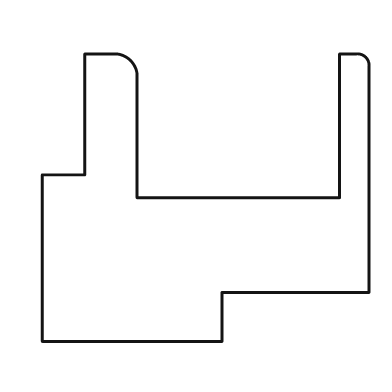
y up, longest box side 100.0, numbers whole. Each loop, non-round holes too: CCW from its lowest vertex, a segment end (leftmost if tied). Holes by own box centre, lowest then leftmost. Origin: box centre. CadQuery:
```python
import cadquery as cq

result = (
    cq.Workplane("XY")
    .moveTo(-50.0, -44.0)
    .lineTo(5.0, -44.0)
    .lineTo(5.0, -29.0)
    .lineTo(50.0, -29.0)
    .lineTo(50.0, 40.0)
    .threePointArc((49.0, 43.0), (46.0, 44.0))
    .lineTo(41.0, 44.0)
    .lineTo(41.0, 0.0)
    .lineTo(-21.0, 0.0)
    .lineTo(-21.0, 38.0)
    .threePointArc((-23.0, 42.0), (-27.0, 44.0))
    .lineTo(-37.0, 44.0)
    .lineTo(-37.0, 7.0)
    .lineTo(-50.0, 7.0)
    .close()
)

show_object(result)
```